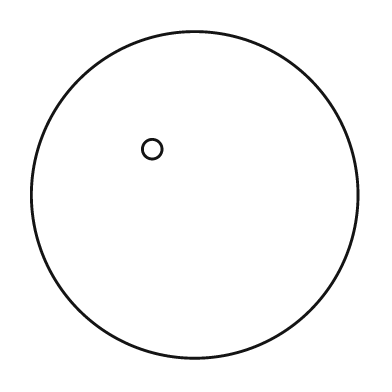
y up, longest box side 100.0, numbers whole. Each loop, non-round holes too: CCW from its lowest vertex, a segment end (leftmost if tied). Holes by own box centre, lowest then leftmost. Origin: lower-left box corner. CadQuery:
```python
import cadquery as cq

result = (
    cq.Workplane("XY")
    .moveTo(50.0, 50.0)
    .circle(50.0)
    .moveTo(37.0, 64.0)
    .circle(3.0)
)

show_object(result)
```